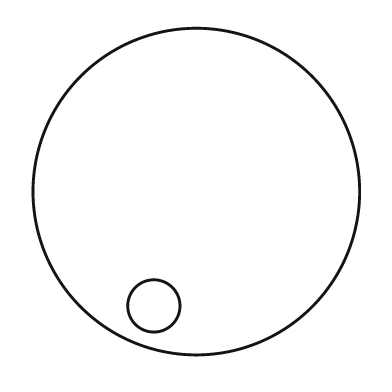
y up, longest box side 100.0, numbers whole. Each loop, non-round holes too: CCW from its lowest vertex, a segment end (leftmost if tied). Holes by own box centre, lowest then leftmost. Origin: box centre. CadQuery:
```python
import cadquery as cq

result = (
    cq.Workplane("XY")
    .moveTo(0.0, 0.0)
    .circle(50.0)
    .moveTo(-13.0, -35.0)
    .circle(8.0)
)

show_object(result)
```